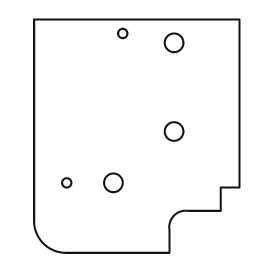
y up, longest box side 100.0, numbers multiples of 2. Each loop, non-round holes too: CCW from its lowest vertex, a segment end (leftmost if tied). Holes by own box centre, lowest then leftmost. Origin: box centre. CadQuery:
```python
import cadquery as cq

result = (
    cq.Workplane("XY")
    .moveTo(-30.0, -50.0)
    .lineTo(14.0, -50.0)
    .lineTo(14.0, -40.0)
    .threePointArc((16.0, -34.0), (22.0, -32.0))
    .lineTo(36.0, -32.0)
    .lineTo(36.0, -22.0)
    .lineTo(44.0, -22.0)
    .lineTo(44.0, 50.0)
    .lineTo(-44.0, 50.0)
    .lineTo(-44.0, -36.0)
    .threePointArc((-40.0, -46.0), (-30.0, -50.0))
    .close()
    .moveTo(-30.0, -20.0)
    .circle(2.0)
    .moveTo(-10.0, -20.0)
    .circle(4.0)
    .moveTo(16.0, 2.0)
    .circle(4.0)
    .moveTo(16.0, 40.0)
    .circle(4.0)
    .moveTo(-6.0, 44.0)
    .circle(2.0)
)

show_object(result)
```